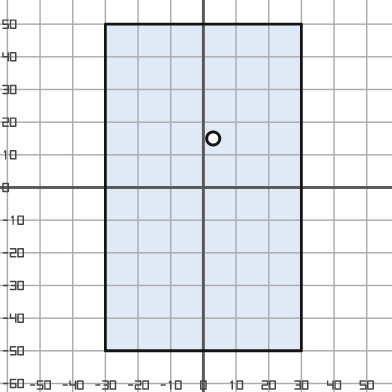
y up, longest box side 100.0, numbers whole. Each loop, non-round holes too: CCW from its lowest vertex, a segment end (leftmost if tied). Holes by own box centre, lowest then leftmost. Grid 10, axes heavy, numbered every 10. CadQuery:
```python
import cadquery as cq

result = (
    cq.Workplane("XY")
    .moveTo(-30.0, -50.0)
    .lineTo(30.0, -50.0)
    .lineTo(30.0, 50.0)
    .lineTo(-30.0, 50.0)
    .close()
    .moveTo(3.0, 15.0)
    .circle(2.0)
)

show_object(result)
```